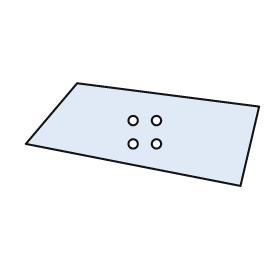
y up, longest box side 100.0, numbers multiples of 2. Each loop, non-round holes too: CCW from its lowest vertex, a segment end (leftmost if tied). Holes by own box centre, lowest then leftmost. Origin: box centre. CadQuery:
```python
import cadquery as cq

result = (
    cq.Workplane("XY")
    .moveTo(42.0, -22.0)
    .lineTo(50.0, 12.0)
    .lineTo(-28.0, 22.0)
    .lineTo(-50.0, -4.0)
    .close()
    .moveTo(-4.0, -4.0)
    .circle(2.0)
    .moveTo(6.0, -4.0)
    .circle(2.0)
    .moveTo(-4.0, 6.0)
    .circle(2.0)
    .moveTo(6.0, 6.0)
    .circle(2.0)
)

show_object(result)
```